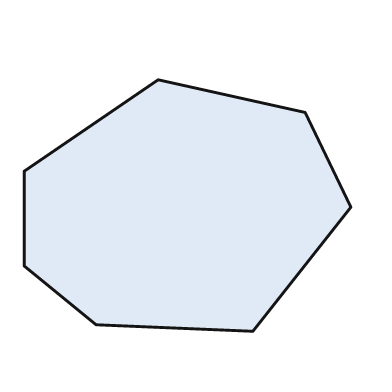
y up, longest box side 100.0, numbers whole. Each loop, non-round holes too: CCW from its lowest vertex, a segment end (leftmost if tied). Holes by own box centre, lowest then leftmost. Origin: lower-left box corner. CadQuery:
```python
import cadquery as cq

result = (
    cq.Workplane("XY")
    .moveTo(70.0, 0.0)
    .lineTo(100.0, 38.0)
    .lineTo(86.0, 67.0)
    .lineTo(41.0, 77.0)
    .lineTo(0.0, 49.0)
    .lineTo(0.0, 20.0)
    .lineTo(22.0, 2.0)
    .close()
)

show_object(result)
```